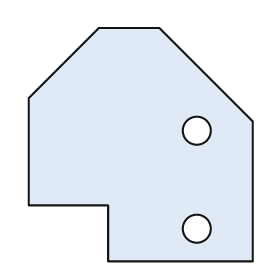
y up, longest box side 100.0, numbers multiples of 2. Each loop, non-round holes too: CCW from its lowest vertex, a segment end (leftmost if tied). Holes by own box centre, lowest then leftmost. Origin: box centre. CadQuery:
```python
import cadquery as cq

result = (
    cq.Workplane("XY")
    .moveTo(-14.0, -50.0)
    .lineTo(48.0, -50.0)
    .lineTo(48.0, 10.0)
    .lineTo(8.0, 50.0)
    .lineTo(-18.0, 50.0)
    .lineTo(-48.0, 20.0)
    .lineTo(-48.0, -26.0)
    .lineTo(-14.0, -26.0)
    .close()
    .moveTo(24.0, -36.0)
    .circle(6.0)
    .moveTo(24.0, 6.0)
    .circle(6.0)
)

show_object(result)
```